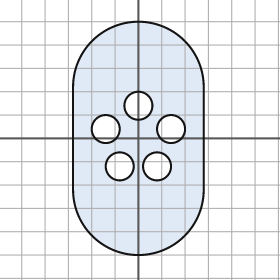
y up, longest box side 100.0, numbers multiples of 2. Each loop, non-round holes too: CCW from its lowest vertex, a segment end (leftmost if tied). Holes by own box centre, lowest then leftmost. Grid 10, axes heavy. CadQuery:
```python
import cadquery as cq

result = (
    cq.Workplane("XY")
    .moveTo(-28.0, -22.0)
    .threePointArc((0.0, -50.0), (28.0, -22.0))
    .lineTo(28.0, 22.0)
    .threePointArc((0.0, 50.0), (-28.0, 22.0))
    .close()
    .moveTo(-8.0, -12.0)
    .circle(6.0)
    .moveTo(8.0, -12.0)
    .circle(6.0)
    .moveTo(-14.0, 4.0)
    .circle(6.0)
    .moveTo(14.0, 4.0)
    .circle(6.0)
    .moveTo(0.0, 14.0)
    .circle(6.0)
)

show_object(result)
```